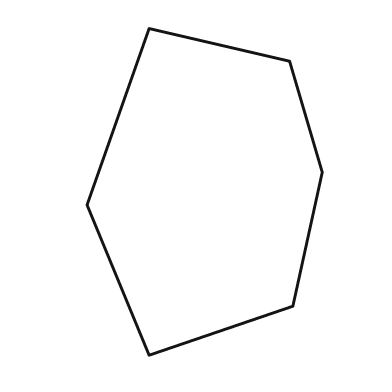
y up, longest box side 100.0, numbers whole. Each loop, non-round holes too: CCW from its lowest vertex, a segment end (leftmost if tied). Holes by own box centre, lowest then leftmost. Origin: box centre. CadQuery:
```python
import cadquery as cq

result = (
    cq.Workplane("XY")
    .moveTo(-17.0, -50.0)
    .lineTo(27.0, -35.0)
    .lineTo(36.0, 6.0)
    .lineTo(26.0, 40.0)
    .lineTo(-17.0, 50.0)
    .lineTo(-36.0, -4.0)
    .close()
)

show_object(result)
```